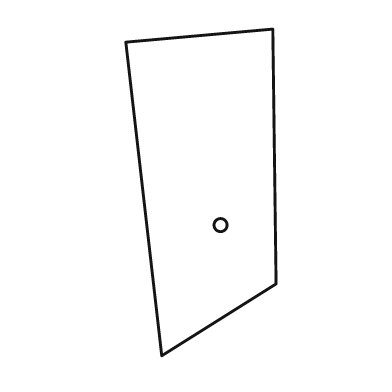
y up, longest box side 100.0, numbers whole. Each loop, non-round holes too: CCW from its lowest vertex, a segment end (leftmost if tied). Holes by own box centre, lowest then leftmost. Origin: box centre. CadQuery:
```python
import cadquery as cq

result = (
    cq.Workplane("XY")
    .moveTo(-12.0, -50.0)
    .lineTo(23.0, -28.0)
    .lineTo(22.0, 50.0)
    .lineTo(-23.0, 46.0)
    .close()
    .moveTo(6.0, -10.0)
    .circle(2.0)
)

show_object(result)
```